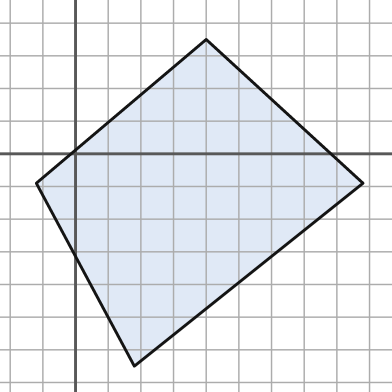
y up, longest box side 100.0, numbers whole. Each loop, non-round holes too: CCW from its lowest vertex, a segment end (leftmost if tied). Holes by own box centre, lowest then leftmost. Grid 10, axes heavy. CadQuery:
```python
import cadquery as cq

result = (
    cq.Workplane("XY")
    .moveTo(18.0, -65.0)
    .lineTo(88.0, -9.0)
    .lineTo(40.0, 35.0)
    .lineTo(-12.0, -9.0)
    .close()
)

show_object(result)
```